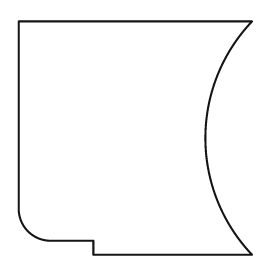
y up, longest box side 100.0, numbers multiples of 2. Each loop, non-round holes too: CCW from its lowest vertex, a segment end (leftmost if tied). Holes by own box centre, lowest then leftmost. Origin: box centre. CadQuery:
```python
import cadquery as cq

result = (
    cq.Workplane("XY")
    .moveTo(-18.0, -50.0)
    .lineTo(50.0, -50.0)
    .threePointArc((30.0, 0.0), (50.0, 50.0))
    .lineTo(-50.0, 50.0)
    .lineTo(-50.0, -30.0)
    .threePointArc((-46.0, -40.0), (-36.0, -44.0))
    .lineTo(-18.0, -44.0)
    .close()
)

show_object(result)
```